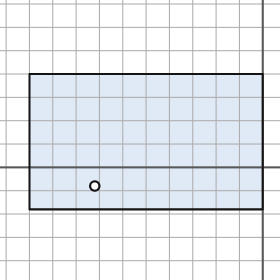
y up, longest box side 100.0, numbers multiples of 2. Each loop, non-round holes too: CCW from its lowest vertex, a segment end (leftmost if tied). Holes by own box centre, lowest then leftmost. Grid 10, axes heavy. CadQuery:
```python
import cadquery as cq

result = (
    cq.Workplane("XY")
    .moveTo(-100.0, -18.0)
    .lineTo(0.0, -18.0)
    .lineTo(0.0, 40.0)
    .lineTo(-100.0, 40.0)
    .close()
    .moveTo(-72.0, -8.0)
    .circle(2.0)
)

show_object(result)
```